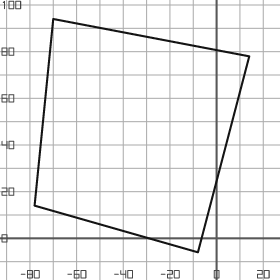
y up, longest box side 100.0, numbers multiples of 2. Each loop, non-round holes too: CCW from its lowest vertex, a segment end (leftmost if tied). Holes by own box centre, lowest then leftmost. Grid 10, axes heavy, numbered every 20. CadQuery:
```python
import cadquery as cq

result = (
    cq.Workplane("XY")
    .moveTo(-8.0, -6.0)
    .lineTo(14.0, 78.0)
    .lineTo(-70.0, 94.0)
    .lineTo(-78.0, 14.0)
    .close()
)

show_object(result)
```